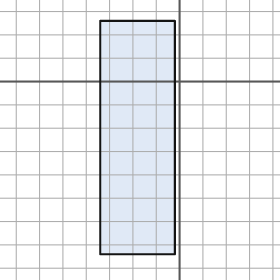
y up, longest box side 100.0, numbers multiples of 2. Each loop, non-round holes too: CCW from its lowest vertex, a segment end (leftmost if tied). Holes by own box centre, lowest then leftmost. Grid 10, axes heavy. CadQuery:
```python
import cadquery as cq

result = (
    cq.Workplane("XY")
    .moveTo(-34.0, -74.0)
    .lineTo(-2.0, -74.0)
    .lineTo(-2.0, 26.0)
    .lineTo(-34.0, 26.0)
    .close()
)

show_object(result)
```